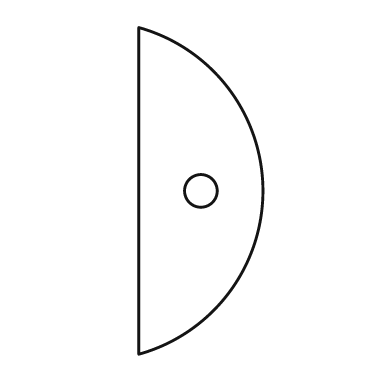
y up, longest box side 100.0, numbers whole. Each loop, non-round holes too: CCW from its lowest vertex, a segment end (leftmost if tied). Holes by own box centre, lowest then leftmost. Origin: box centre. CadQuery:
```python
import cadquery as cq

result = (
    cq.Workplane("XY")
    .moveTo(-19.0, -50.0)
    .threePointArc((19.0, 0.0), (-19.0, 50.0))
    .close()
    .moveTo(0.0, 0.0)
    .circle(5.0)
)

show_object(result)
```